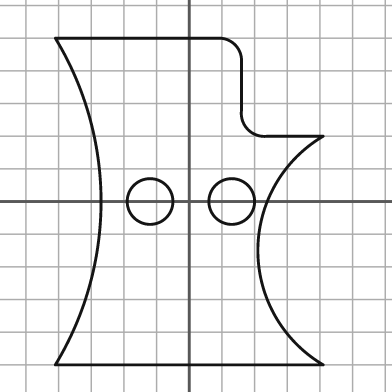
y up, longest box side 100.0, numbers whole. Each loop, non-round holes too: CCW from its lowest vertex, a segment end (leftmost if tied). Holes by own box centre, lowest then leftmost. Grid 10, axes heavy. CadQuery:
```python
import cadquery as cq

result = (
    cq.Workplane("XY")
    .moveTo(-41.0, -50.0)
    .lineTo(41.0, -50.0)
    .threePointArc((21.0, -15.0), (41.0, 20.0))
    .lineTo(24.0, 20.0)
    .threePointArc((18.0, 22.0), (16.0, 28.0))
    .lineTo(16.0, 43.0)
    .threePointArc((14.0, 48.0), (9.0, 50.0))
    .lineTo(-41.0, 50.0)
    .threePointArc((-27.0, 0.0), (-41.0, -50.0))
    .close()
    .moveTo(-12.0, 0.0)
    .circle(7.0)
    .moveTo(13.0, 0.0)
    .circle(7.0)
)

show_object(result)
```